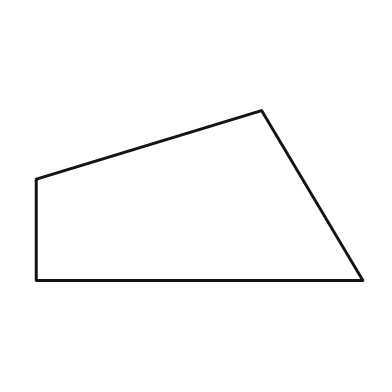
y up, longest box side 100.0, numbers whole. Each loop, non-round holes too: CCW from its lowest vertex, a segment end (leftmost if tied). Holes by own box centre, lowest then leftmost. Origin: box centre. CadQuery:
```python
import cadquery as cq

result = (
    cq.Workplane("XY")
    .moveTo(-50.0, -26.0)
    .lineTo(50.0, -26.0)
    .lineTo(19.0, 26.0)
    .lineTo(-50.0, 5.0)
    .close()
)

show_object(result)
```